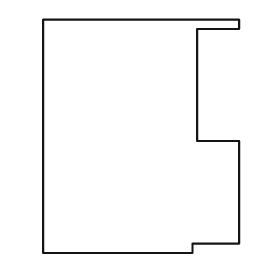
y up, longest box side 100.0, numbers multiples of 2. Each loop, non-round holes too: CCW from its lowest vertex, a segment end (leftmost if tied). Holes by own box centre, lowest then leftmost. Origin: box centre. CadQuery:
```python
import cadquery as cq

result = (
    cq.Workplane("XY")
    .moveTo(-42.0, -50.0)
    .lineTo(22.0, -50.0)
    .lineTo(22.0, -46.0)
    .lineTo(42.0, -46.0)
    .lineTo(42.0, -2.0)
    .lineTo(24.0, -2.0)
    .lineTo(24.0, 46.0)
    .lineTo(42.0, 46.0)
    .lineTo(42.0, 50.0)
    .lineTo(-42.0, 50.0)
    .close()
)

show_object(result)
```